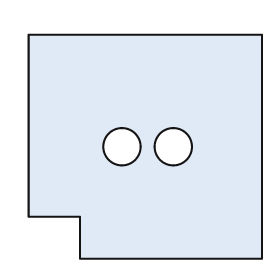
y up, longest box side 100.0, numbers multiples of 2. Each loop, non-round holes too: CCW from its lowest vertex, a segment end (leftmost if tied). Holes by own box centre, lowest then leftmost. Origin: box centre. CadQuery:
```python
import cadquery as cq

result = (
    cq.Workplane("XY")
    .moveTo(-28.0, -48.0)
    .lineTo(50.0, -48.0)
    .lineTo(50.0, 48.0)
    .lineTo(-50.0, 48.0)
    .lineTo(-50.0, -30.0)
    .lineTo(-28.0, -30.0)
    .close()
    .moveTo(-10.0, 0.0)
    .circle(8.0)
    .moveTo(12.0, 0.0)
    .circle(8.0)
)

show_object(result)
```